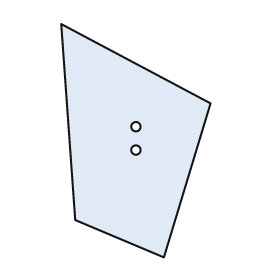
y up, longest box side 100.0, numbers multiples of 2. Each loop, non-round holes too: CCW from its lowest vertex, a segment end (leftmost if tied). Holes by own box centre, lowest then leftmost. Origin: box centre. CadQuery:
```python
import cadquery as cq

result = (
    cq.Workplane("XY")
    .moveTo(12.0, -50.0)
    .lineTo(32.0, 16.0)
    .lineTo(-32.0, 50.0)
    .lineTo(-26.0, -34.0)
    .close()
    .moveTo(0.0, -4.0)
    .circle(2.0)
    .moveTo(0.0, 6.0)
    .circle(2.0)
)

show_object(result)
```